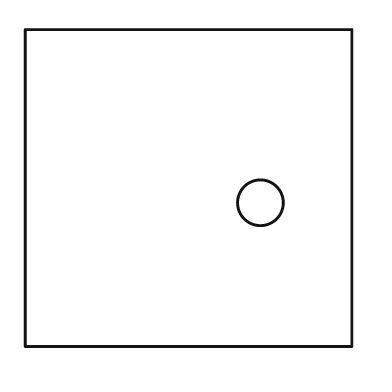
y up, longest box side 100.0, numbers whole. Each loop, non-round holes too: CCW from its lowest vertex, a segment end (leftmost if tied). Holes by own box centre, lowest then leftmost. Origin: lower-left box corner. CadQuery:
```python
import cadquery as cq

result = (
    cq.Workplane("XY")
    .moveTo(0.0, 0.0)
    .lineTo(100.0, 0.0)
    .lineTo(100.0, 97.0)
    .lineTo(0.0, 97.0)
    .close()
    .moveTo(72.0, 44.0)
    .circle(7.0)
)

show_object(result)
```